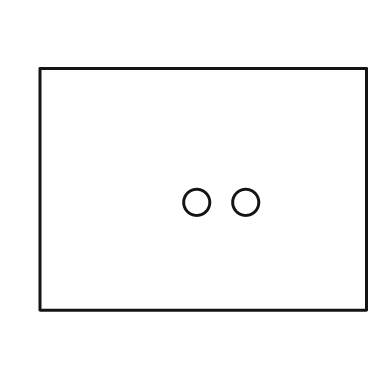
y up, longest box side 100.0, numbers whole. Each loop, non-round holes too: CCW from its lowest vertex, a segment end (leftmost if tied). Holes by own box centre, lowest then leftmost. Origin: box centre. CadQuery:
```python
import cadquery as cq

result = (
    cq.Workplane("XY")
    .moveTo(-50.0, -37.0)
    .lineTo(50.0, -37.0)
    .lineTo(50.0, 37.0)
    .lineTo(-50.0, 37.0)
    .close()
    .moveTo(-2.0, -4.0)
    .circle(4.0)
    .moveTo(13.0, -4.0)
    .circle(4.0)
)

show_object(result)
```